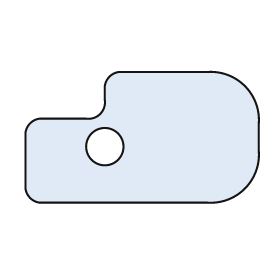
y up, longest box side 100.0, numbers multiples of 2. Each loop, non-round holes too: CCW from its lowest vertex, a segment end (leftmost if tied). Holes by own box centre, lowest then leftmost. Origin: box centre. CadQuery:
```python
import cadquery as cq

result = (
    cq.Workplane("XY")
    .moveTo(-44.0, -28.0)
    .lineTo(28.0, -28.0)
    .threePointArc((44.0, -22.0), (50.0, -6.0))
    .lineTo(50.0, 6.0)
    .threePointArc((44.0, 22.0), (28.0, 28.0))
    .lineTo(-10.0, 28.0)
    .threePointArc((-14.0, 26.0), (-16.0, 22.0))
    .lineTo(-16.0, 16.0)
    .threePointArc((-18.0, 10.0), (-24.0, 8.0))
    .lineTo(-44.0, 8.0)
    .threePointArc((-48.0, 6.0), (-50.0, 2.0))
    .lineTo(-50.0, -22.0)
    .threePointArc((-48.0, -26.0), (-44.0, -28.0))
    .close()
    .moveTo(-16.0, -4.0)
    .circle(8.0)
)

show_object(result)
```